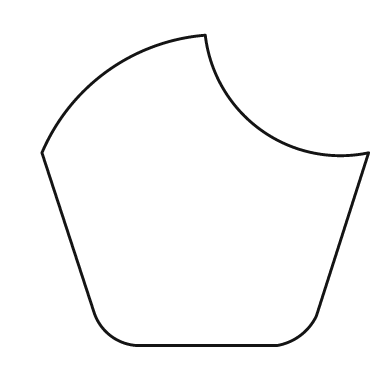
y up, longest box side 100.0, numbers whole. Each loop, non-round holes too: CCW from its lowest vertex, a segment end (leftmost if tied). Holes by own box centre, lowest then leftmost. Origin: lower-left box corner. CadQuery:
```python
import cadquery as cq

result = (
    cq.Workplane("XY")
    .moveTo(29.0, 0.0)
    .lineTo(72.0, 0.0)
    .threePointArc((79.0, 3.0), (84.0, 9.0))
    .lineTo(100.0, 59.0)
    .threePointArc((67.0, 66.0), (50.0, 95.0))
    .threePointArc((20.0, 84.0), (0.0, 59.0))
    .lineTo(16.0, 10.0)
    .threePointArc((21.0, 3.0), (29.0, 0.0))
    .close()
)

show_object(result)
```